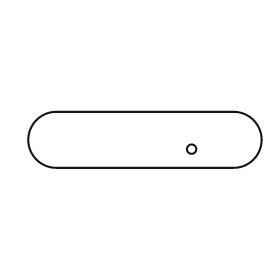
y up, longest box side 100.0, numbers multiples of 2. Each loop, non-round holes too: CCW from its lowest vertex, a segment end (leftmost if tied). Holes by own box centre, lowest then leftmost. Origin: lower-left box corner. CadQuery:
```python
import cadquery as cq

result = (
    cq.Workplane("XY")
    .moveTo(12.0, 0.0)
    .lineTo(88.0, 0.0)
    .threePointArc((100.0, 12.0), (88.0, 24.0))
    .lineTo(12.0, 24.0)
    .threePointArc((0.0, 12.0), (12.0, 0.0))
    .close()
    .moveTo(70.0, 8.0)
    .circle(2.0)
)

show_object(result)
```